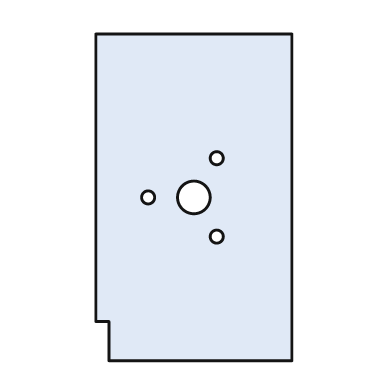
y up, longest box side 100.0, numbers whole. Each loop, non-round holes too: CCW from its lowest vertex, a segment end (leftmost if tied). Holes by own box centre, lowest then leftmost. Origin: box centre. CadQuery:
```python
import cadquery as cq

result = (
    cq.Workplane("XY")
    .moveTo(-26.0, -50.0)
    .lineTo(30.0, -50.0)
    .lineTo(30.0, 50.0)
    .lineTo(-30.0, 50.0)
    .lineTo(-30.0, -38.0)
    .lineTo(-26.0, -38.0)
    .close()
    .moveTo(7.0, -12.0)
    .circle(2.0)
    .moveTo(-14.0, 0.0)
    .circle(2.0)
    .moveTo(0.0, 0.0)
    .circle(5.0)
    .moveTo(7.0, 12.0)
    .circle(2.0)
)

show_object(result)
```